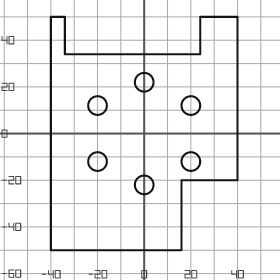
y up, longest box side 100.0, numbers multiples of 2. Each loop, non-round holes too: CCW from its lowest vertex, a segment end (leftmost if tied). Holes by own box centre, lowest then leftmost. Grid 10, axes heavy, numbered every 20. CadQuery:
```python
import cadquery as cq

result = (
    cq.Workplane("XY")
    .moveTo(-40.0, -50.0)
    .lineTo(16.0, -50.0)
    .lineTo(16.0, -20.0)
    .lineTo(40.0, -20.0)
    .lineTo(40.0, 50.0)
    .lineTo(24.0, 50.0)
    .lineTo(24.0, 34.0)
    .lineTo(-34.0, 34.0)
    .lineTo(-34.0, 50.0)
    .lineTo(-40.0, 50.0)
    .close()
    .moveTo(0.0, -22.0)
    .circle(4.0)
    .moveTo(-20.0, -12.0)
    .circle(4.0)
    .moveTo(20.0, -12.0)
    .circle(4.0)
    .moveTo(-20.0, 12.0)
    .circle(4.0)
    .moveTo(20.0, 12.0)
    .circle(4.0)
    .moveTo(0.0, 22.0)
    .circle(4.0)
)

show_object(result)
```